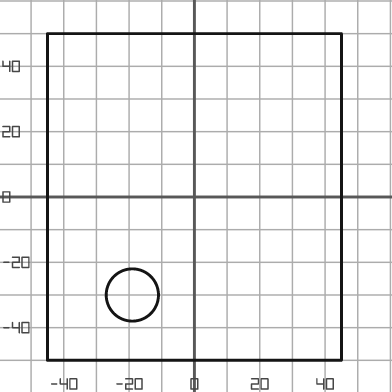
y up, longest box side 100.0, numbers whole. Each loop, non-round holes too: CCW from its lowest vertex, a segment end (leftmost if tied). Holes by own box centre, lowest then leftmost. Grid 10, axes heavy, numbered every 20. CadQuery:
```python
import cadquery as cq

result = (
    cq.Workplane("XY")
    .moveTo(-45.0, -50.0)
    .lineTo(45.0, -50.0)
    .lineTo(45.0, 50.0)
    .lineTo(-45.0, 50.0)
    .close()
    .moveTo(-19.0, -30.0)
    .circle(8.0)
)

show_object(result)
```